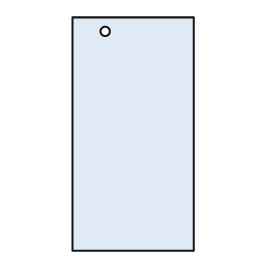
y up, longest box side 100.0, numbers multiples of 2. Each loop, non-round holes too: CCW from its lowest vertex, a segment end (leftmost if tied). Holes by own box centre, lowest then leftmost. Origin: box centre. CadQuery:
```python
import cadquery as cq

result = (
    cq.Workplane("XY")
    .moveTo(-26.0, -50.0)
    .lineTo(26.0, -50.0)
    .lineTo(26.0, 50.0)
    .lineTo(-26.0, 50.0)
    .close()
    .moveTo(-12.0, 44.0)
    .circle(2.0)
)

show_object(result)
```